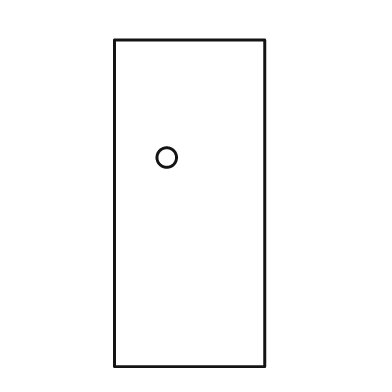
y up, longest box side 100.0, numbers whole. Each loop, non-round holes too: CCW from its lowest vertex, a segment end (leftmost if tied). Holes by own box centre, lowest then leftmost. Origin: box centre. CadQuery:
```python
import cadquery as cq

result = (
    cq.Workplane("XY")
    .moveTo(-23.0, -50.0)
    .lineTo(23.0, -50.0)
    .lineTo(23.0, 50.0)
    .lineTo(-23.0, 50.0)
    .close()
    .moveTo(-7.0, 14.0)
    .circle(3.0)
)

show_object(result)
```